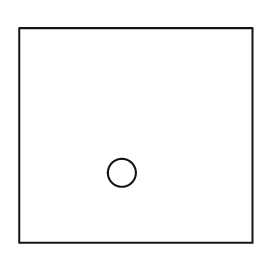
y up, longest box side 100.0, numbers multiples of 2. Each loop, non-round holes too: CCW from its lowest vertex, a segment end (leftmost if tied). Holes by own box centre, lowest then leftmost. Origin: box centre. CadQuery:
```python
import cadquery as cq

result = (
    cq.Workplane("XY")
    .moveTo(-50.0, -46.0)
    .lineTo(50.0, -46.0)
    .lineTo(50.0, 46.0)
    .lineTo(-50.0, 46.0)
    .close()
    .moveTo(-6.0, -16.0)
    .circle(6.0)
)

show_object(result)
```